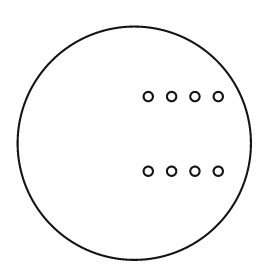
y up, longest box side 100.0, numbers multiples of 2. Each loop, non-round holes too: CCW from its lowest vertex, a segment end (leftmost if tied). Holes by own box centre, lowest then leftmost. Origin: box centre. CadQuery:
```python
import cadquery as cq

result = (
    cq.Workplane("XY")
    .moveTo(0.0, 0.0)
    .circle(50.0)
    .moveTo(6.0, -12.0)
    .circle(2.0)
    .moveTo(16.0, -12.0)
    .circle(2.0)
    .moveTo(26.0, -12.0)
    .circle(2.0)
    .moveTo(36.0, -12.0)
    .circle(2.0)
    .moveTo(6.0, 20.0)
    .circle(2.0)
    .moveTo(16.0, 20.0)
    .circle(2.0)
    .moveTo(26.0, 20.0)
    .circle(2.0)
    .moveTo(36.0, 20.0)
    .circle(2.0)
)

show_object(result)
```